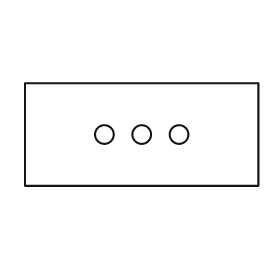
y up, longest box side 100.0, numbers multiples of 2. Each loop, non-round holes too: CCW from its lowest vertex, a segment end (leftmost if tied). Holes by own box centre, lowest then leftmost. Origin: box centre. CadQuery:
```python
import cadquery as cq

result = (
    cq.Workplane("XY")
    .moveTo(-50.0, -22.0)
    .lineTo(50.0, -22.0)
    .lineTo(50.0, 22.0)
    .lineTo(-50.0, 22.0)
    .close()
    .moveTo(-16.0, 0.0)
    .circle(4.0)
    .moveTo(0.0, 0.0)
    .circle(4.0)
    .moveTo(16.0, 0.0)
    .circle(4.0)
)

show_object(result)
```